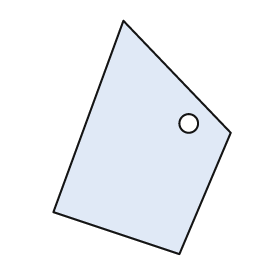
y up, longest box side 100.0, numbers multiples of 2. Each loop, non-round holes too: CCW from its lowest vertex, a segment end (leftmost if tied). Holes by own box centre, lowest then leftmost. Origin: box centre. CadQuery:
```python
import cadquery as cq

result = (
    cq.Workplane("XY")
    .moveTo(16.0, -50.0)
    .lineTo(38.0, 2.0)
    .lineTo(-8.0, 50.0)
    .lineTo(-38.0, -32.0)
    .close()
    .moveTo(20.0, 6.0)
    .circle(4.0)
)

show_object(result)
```